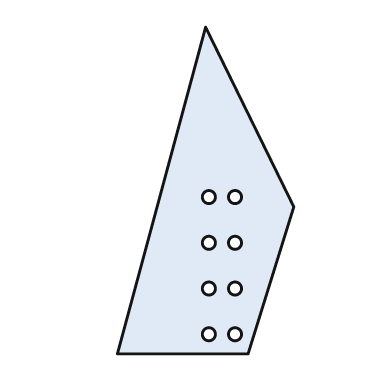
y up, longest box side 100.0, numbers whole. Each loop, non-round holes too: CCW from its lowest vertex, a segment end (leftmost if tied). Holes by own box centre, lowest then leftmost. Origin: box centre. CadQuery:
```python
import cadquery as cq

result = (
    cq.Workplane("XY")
    .moveTo(-27.0, -50.0)
    .lineTo(13.0, -50.0)
    .lineTo(27.0, -5.0)
    .lineTo(0.0, 50.0)
    .close()
    .moveTo(1.0, -44.0)
    .circle(2.0)
    .moveTo(9.0, -44.0)
    .circle(2.0)
    .moveTo(1.0, -30.0)
    .circle(2.0)
    .moveTo(9.0, -30.0)
    .circle(2.0)
    .moveTo(1.0, -16.0)
    .circle(2.0)
    .moveTo(9.0, -16.0)
    .circle(2.0)
    .moveTo(1.0, -2.0)
    .circle(2.0)
    .moveTo(9.0, -2.0)
    .circle(2.0)
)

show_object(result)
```